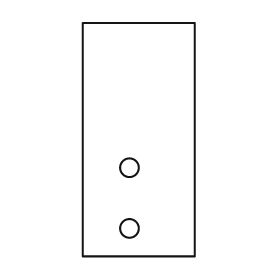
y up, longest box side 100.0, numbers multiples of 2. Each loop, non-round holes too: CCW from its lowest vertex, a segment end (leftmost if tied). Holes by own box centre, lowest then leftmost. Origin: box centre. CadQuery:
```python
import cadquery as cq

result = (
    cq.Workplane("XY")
    .moveTo(-24.0, -50.0)
    .lineTo(24.0, -50.0)
    .lineTo(24.0, 50.0)
    .lineTo(-24.0, 50.0)
    .close()
    .moveTo(-4.0, -38.0)
    .circle(4.0)
    .moveTo(-4.0, -12.0)
    .circle(4.0)
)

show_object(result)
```